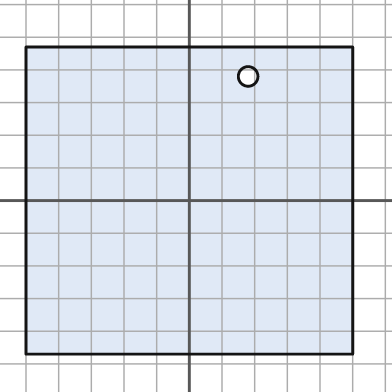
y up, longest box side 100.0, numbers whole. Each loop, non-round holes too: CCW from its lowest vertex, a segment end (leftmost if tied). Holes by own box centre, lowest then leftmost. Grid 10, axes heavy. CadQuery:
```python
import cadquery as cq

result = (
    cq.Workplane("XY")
    .moveTo(-50.0, -47.0)
    .lineTo(50.0, -47.0)
    .lineTo(50.0, 47.0)
    .lineTo(-50.0, 47.0)
    .close()
    .moveTo(18.0, 38.0)
    .circle(3.0)
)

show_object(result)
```